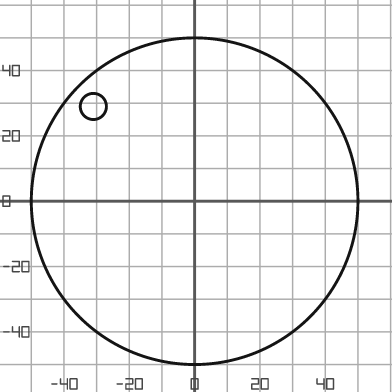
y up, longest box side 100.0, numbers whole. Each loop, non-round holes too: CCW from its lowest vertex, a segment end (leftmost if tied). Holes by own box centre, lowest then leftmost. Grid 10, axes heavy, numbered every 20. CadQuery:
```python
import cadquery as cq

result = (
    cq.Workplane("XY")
    .moveTo(0.0, 0.0)
    .circle(50.0)
    .moveTo(-31.0, 29.0)
    .circle(4.0)
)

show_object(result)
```